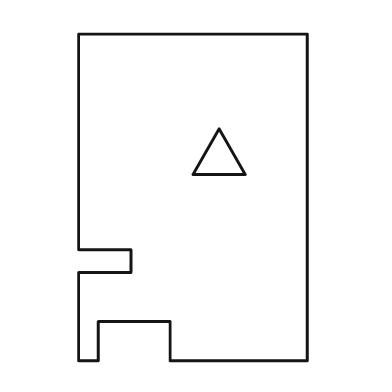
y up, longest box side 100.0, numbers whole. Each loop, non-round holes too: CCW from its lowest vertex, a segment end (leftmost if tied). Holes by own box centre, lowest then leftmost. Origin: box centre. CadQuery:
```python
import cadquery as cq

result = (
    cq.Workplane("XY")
    .moveTo(-35.0, -50.0)
    .lineTo(-29.0, -50.0)
    .lineTo(-29.0, -38.0)
    .lineTo(-7.0, -38.0)
    .lineTo(-7.0, -50.0)
    .lineTo(35.0, -50.0)
    .lineTo(35.0, 50.0)
    .lineTo(-35.0, 50.0)
    .lineTo(-35.0, -16.0)
    .lineTo(-19.0, -16.0)
    .lineTo(-19.0, -23.0)
    .lineTo(-35.0, -23.0)
    .close()
    .moveTo(0.0, 7.0)
    .lineTo(16.0, 7.0)
    .lineTo(8.0, 21.0)
    .close()
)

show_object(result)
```